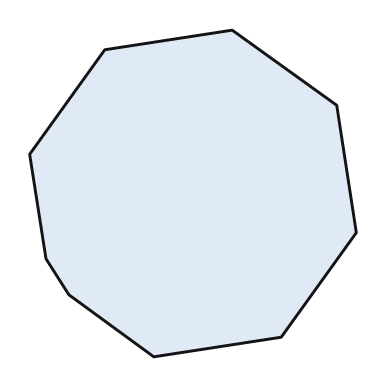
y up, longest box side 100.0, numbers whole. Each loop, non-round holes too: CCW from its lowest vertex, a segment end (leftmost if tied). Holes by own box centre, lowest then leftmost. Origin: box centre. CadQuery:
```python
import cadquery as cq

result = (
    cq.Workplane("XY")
    .moveTo(-12.0, -50.0)
    .lineTo(27.0, -44.0)
    .lineTo(50.0, -12.0)
    .lineTo(44.0, 27.0)
    .lineTo(12.0, 50.0)
    .lineTo(-27.0, 44.0)
    .lineTo(-50.0, 12.0)
    .lineTo(-45.0, -20.0)
    .lineTo(-38.0, -31.0)
    .close()
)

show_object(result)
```